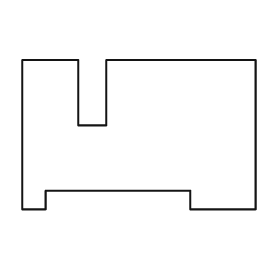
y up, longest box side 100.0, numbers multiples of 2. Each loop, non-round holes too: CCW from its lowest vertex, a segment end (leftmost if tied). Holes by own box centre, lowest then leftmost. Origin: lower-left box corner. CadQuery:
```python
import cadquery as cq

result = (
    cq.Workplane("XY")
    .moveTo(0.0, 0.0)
    .lineTo(10.0, 0.0)
    .lineTo(10.0, 8.0)
    .lineTo(72.0, 8.0)
    .lineTo(72.0, 0.0)
    .lineTo(100.0, 0.0)
    .lineTo(100.0, 64.0)
    .lineTo(36.0, 64.0)
    .lineTo(36.0, 36.0)
    .lineTo(24.0, 36.0)
    .lineTo(24.0, 64.0)
    .lineTo(0.0, 64.0)
    .close()
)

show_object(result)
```